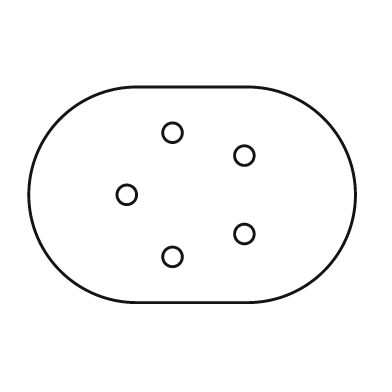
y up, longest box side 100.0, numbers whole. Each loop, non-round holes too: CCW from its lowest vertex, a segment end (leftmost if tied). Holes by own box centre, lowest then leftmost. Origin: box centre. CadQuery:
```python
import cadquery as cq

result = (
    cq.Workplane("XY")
    .moveTo(-17.0, -33.0)
    .lineTo(17.0, -33.0)
    .threePointArc((50.0, 0.0), (17.0, 33.0))
    .lineTo(-17.0, 33.0)
    .threePointArc((-50.0, 0.0), (-17.0, -33.0))
    .close()
    .moveTo(-6.0, -19.0)
    .circle(3.0)
    .moveTo(16.0, -12.0)
    .circle(3.0)
    .moveTo(-20.0, 0.0)
    .circle(3.0)
    .moveTo(16.0, 12.0)
    .circle(3.0)
    .moveTo(-6.0, 19.0)
    .circle(3.0)
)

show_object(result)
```